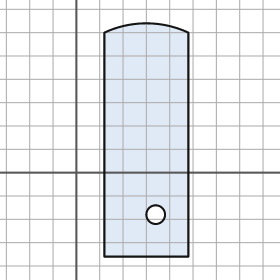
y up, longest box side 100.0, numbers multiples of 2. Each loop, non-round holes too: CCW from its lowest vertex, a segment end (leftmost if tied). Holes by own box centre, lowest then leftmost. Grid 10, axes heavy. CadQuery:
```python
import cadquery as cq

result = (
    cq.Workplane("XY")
    .moveTo(12.0, -36.0)
    .lineTo(48.0, -36.0)
    .lineTo(48.0, 60.0)
    .threePointArc((30.0, 64.0), (12.0, 60.0))
    .close()
    .moveTo(34.0, -18.0)
    .circle(4.0)
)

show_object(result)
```